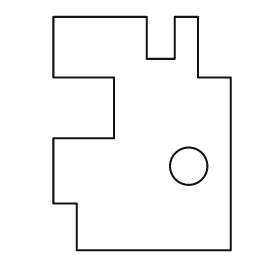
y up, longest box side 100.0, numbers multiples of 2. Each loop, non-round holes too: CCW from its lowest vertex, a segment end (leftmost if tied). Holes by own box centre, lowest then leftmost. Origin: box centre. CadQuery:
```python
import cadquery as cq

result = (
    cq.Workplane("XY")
    .moveTo(-28.0, -50.0)
    .lineTo(38.0, -50.0)
    .lineTo(38.0, 24.0)
    .lineTo(24.0, 24.0)
    .lineTo(24.0, 50.0)
    .lineTo(14.0, 50.0)
    .lineTo(14.0, 32.0)
    .lineTo(2.0, 32.0)
    .lineTo(2.0, 50.0)
    .lineTo(-38.0, 50.0)
    .lineTo(-38.0, 24.0)
    .lineTo(-12.0, 24.0)
    .lineTo(-12.0, -2.0)
    .lineTo(-38.0, -2.0)
    .lineTo(-38.0, -30.0)
    .lineTo(-28.0, -30.0)
    .close()
    .moveTo(20.0, -14.0)
    .circle(8.0)
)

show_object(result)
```